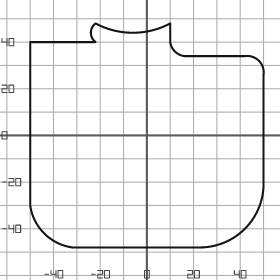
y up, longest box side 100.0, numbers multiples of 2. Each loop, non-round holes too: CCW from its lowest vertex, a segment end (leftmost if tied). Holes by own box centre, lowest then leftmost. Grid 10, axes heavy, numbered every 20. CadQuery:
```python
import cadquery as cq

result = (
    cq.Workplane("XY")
    .moveTo(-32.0, -48.0)
    .lineTo(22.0, -48.0)
    .threePointArc((42.0, -40.0), (50.0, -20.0))
    .lineTo(50.0, 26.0)
    .threePointArc((48.0, 32.0), (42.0, 34.0))
    .lineTo(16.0, 34.0)
    .threePointArc((12.0, 36.0), (10.0, 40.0))
    .lineTo(10.0, 48.0)
    .threePointArc((-6.0, 44.0), (-22.0, 48.0))
    .threePointArc((-24.0, 44.0), (-22.0, 40.0))
    .lineTo(-50.0, 40.0)
    .lineTo(-50.0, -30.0)
    .threePointArc((-44.0, -42.0), (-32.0, -48.0))
    .close()
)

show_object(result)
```